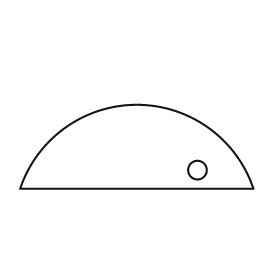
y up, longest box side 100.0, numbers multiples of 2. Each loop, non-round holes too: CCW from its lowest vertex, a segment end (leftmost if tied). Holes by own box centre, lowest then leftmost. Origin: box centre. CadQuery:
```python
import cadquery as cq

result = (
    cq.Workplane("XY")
    .moveTo(-50.0, -18.0)
    .lineTo(50.0, -18.0)
    .threePointArc((0.0, 18.0), (-50.0, -18.0))
    .close()
    .moveTo(26.0, -10.0)
    .circle(4.0)
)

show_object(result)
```